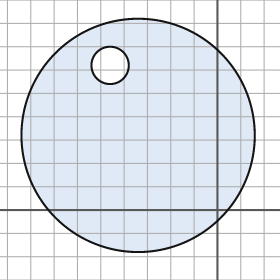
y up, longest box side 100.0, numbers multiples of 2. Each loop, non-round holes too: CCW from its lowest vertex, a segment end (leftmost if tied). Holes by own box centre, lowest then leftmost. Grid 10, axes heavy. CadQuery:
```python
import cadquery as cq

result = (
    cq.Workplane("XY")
    .moveTo(-34.0, 32.0)
    .circle(50.0)
    .moveTo(-46.0, 62.0)
    .circle(8.0)
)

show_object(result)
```